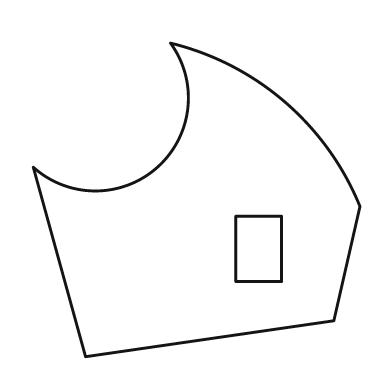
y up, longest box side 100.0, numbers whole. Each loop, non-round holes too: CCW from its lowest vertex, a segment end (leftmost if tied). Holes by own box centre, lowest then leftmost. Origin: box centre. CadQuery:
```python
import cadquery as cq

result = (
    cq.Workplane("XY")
    .moveTo(-34.0, -48.0)
    .lineTo(42.0, -37.0)
    .lineTo(50.0, -2.0)
    .threePointArc((27.0, 30.0), (-8.0, 48.0))
    .threePointArc((-12.0, 10.0), (-50.0, 10.0))
    .close()
    .moveTo(12.0, -25.0)
    .lineTo(26.0, -25.0)
    .lineTo(26.0, -5.0)
    .lineTo(12.0, -5.0)
    .close()
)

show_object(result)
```